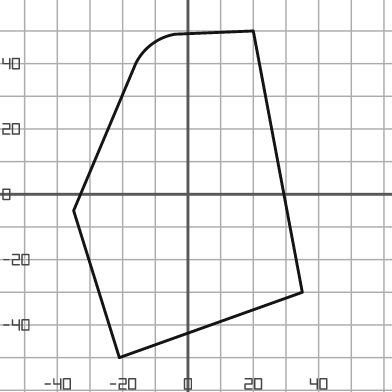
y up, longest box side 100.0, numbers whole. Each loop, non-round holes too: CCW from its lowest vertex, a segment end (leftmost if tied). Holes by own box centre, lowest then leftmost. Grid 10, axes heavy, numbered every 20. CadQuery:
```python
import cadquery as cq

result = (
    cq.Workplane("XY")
    .moveTo(-21.0, -50.0)
    .lineTo(35.0, -30.0)
    .lineTo(20.0, 50.0)
    .lineTo(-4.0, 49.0)
    .threePointArc((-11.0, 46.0), (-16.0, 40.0))
    .lineTo(-35.0, -5.0)
    .close()
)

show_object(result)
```